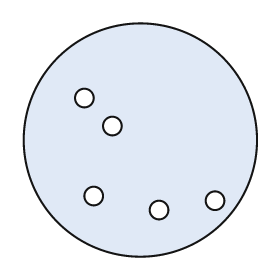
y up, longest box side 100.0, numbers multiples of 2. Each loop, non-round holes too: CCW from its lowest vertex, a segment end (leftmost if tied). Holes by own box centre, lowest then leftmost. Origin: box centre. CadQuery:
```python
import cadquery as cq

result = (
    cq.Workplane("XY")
    .moveTo(0.0, 0.0)
    .circle(50.0)
    .moveTo(8.0, -30.0)
    .circle(4.0)
    .moveTo(32.0, -26.0)
    .circle(4.0)
    .moveTo(-20.0, -24.0)
    .circle(4.0)
    .moveTo(-12.0, 6.0)
    .circle(4.0)
    .moveTo(-24.0, 18.0)
    .circle(4.0)
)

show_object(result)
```